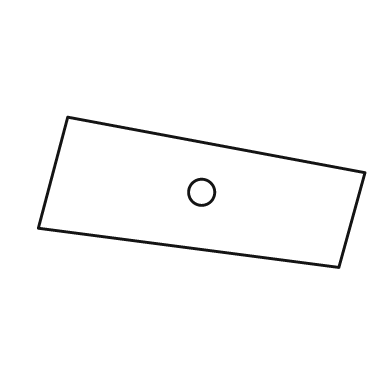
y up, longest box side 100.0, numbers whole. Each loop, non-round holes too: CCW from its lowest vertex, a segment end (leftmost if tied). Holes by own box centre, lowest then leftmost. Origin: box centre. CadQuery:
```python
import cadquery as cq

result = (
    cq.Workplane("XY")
    .moveTo(42.0, -23.0)
    .lineTo(50.0, 6.0)
    .lineTo(-41.0, 23.0)
    .lineTo(-50.0, -11.0)
    .close()
    .moveTo(0.0, 0.0)
    .circle(4.0)
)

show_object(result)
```